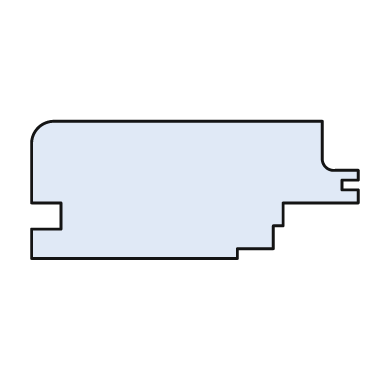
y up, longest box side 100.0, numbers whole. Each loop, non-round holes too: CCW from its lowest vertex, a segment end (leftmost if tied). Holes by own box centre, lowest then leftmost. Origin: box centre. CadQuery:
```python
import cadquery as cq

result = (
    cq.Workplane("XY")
    .moveTo(-50.0, -21.0)
    .lineTo(13.0, -21.0)
    .lineTo(13.0, -18.0)
    .lineTo(24.0, -18.0)
    .lineTo(24.0, -11.0)
    .lineTo(27.0, -11.0)
    .lineTo(27.0, -4.0)
    .lineTo(50.0, -4.0)
    .lineTo(50.0, 0.0)
    .lineTo(45.0, 0.0)
    .lineTo(45.0, 3.0)
    .lineTo(50.0, 3.0)
    .lineTo(50.0, 6.0)
    .lineTo(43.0, 6.0)
    .threePointArc((40.0, 7.0), (39.0, 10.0))
    .lineTo(39.0, 21.0)
    .lineTo(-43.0, 21.0)
    .threePointArc((-48.0, 19.0), (-50.0, 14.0))
    .lineTo(-50.0, -4.0)
    .lineTo(-41.0, -4.0)
    .lineTo(-41.0, -12.0)
    .lineTo(-50.0, -12.0)
    .close()
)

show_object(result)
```